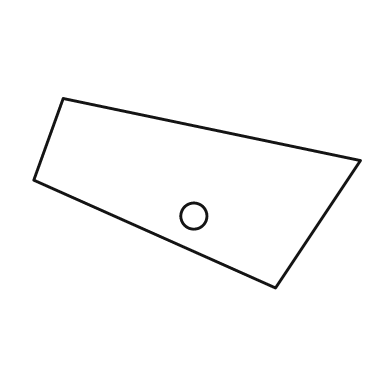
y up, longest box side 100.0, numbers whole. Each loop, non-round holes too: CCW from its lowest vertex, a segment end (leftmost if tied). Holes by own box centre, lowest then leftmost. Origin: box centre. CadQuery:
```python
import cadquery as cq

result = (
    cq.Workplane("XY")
    .moveTo(24.0, -29.0)
    .lineTo(50.0, 10.0)
    .lineTo(-41.0, 29.0)
    .lineTo(-50.0, 4.0)
    .close()
    .moveTo(-1.0, -7.0)
    .circle(4.0)
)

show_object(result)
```